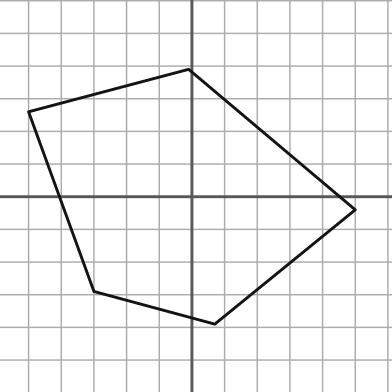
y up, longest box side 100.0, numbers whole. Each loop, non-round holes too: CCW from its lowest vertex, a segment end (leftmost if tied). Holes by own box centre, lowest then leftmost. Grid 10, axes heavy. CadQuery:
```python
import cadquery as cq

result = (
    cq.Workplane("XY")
    .moveTo(7.0, -39.0)
    .lineTo(50.0, -4.0)
    .lineTo(-1.0, 39.0)
    .lineTo(-50.0, 26.0)
    .lineTo(-30.0, -29.0)
    .close()
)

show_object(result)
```